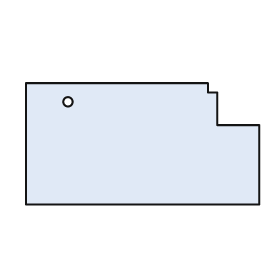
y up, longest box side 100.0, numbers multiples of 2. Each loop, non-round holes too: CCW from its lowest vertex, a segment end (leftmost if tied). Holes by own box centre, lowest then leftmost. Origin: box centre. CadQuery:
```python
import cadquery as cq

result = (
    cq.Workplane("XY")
    .moveTo(-50.0, -26.0)
    .lineTo(50.0, -26.0)
    .lineTo(50.0, 8.0)
    .lineTo(32.0, 8.0)
    .lineTo(32.0, 22.0)
    .lineTo(28.0, 22.0)
    .lineTo(28.0, 26.0)
    .lineTo(-50.0, 26.0)
    .close()
    .moveTo(-32.0, 18.0)
    .circle(2.0)
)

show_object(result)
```